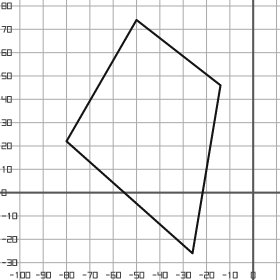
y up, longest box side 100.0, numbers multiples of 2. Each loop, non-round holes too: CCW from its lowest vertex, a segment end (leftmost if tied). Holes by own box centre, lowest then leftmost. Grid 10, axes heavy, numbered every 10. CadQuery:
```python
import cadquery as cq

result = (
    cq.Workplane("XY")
    .moveTo(-26.0, -26.0)
    .lineTo(-14.0, 46.0)
    .lineTo(-50.0, 74.0)
    .lineTo(-80.0, 22.0)
    .close()
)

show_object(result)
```